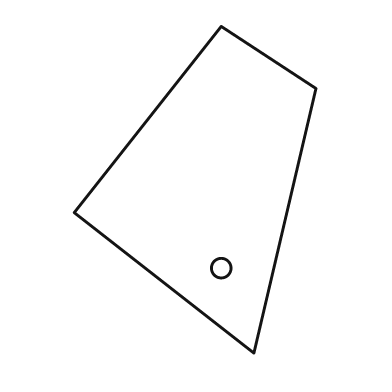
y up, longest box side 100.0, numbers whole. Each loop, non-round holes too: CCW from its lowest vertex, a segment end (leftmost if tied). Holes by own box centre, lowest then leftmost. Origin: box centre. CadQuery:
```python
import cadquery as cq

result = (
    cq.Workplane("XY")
    .moveTo(18.0, -50.0)
    .lineTo(37.0, 31.0)
    .lineTo(8.0, 50.0)
    .lineTo(-37.0, -7.0)
    .close()
    .moveTo(8.0, -24.0)
    .circle(3.0)
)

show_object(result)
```